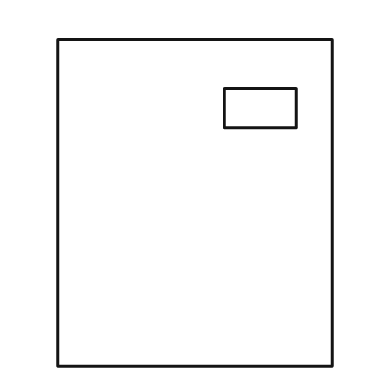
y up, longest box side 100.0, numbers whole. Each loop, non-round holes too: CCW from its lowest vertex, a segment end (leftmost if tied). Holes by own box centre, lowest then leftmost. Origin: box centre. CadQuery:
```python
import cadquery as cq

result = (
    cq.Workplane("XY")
    .moveTo(-42.0, -50.0)
    .lineTo(42.0, -50.0)
    .lineTo(42.0, 50.0)
    .lineTo(-42.0, 50.0)
    .close()
    .moveTo(9.0, 23.0)
    .lineTo(31.0, 23.0)
    .lineTo(31.0, 35.0)
    .lineTo(9.0, 35.0)
    .close()
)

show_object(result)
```